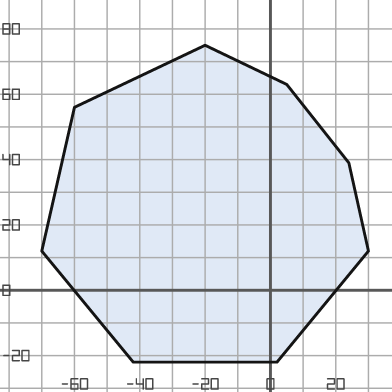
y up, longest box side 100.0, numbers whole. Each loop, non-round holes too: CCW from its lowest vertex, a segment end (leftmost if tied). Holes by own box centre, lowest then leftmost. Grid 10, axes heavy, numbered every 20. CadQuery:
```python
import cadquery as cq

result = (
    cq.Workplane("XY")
    .moveTo(-42.0, -22.0)
    .lineTo(2.0, -22.0)
    .lineTo(30.0, 12.0)
    .lineTo(24.0, 39.0)
    .lineTo(5.0, 63.0)
    .lineTo(-20.0, 75.0)
    .lineTo(-60.0, 56.0)
    .lineTo(-70.0, 12.0)
    .close()
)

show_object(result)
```